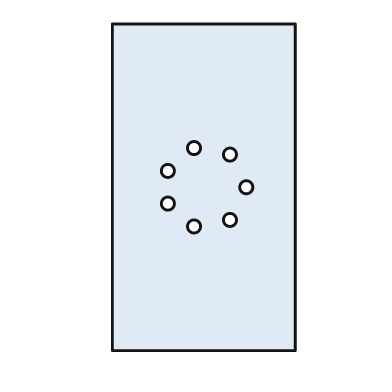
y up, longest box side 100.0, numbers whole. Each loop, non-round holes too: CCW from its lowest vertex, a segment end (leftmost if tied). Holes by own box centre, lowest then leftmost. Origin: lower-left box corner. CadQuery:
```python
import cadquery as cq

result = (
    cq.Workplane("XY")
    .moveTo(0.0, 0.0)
    .lineTo(56.0, 0.0)
    .lineTo(56.0, 100.0)
    .lineTo(0.0, 100.0)
    .close()
    .moveTo(25.0, 38.0)
    .circle(2.0)
    .moveTo(36.0, 40.0)
    .circle(2.0)
    .moveTo(17.0, 45.0)
    .circle(2.0)
    .moveTo(41.0, 50.0)
    .circle(2.0)
    .moveTo(17.0, 55.0)
    .circle(2.0)
    .moveTo(36.0, 60.0)
    .circle(2.0)
    .moveTo(25.0, 62.0)
    .circle(2.0)
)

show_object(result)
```